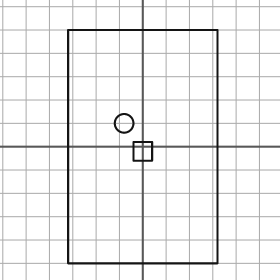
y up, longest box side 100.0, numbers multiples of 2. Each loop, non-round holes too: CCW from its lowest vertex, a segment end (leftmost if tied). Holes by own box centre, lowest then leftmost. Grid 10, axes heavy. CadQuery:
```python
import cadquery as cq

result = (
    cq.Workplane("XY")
    .moveTo(-32.0, -50.0)
    .lineTo(32.0, -50.0)
    .lineTo(32.0, 50.0)
    .lineTo(-32.0, 50.0)
    .close()
    .moveTo(-4.0, -6.0)
    .lineTo(4.0, -6.0)
    .lineTo(4.0, 2.0)
    .lineTo(-4.0, 2.0)
    .close()
    .moveTo(-8.0, 10.0)
    .circle(4.0)
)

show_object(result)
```